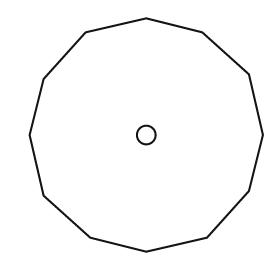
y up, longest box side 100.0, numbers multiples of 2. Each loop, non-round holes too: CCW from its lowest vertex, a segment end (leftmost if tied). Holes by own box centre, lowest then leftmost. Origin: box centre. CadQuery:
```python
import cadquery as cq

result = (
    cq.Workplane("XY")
    .moveTo(0.0, -50.0)
    .lineTo(26.0, -44.0)
    .lineTo(44.0, -24.0)
    .lineTo(50.0, 0.0)
    .lineTo(44.0, 26.0)
    .lineTo(24.0, 44.0)
    .lineTo(0.0, 50.0)
    .lineTo(-26.0, 44.0)
    .lineTo(-44.0, 24.0)
    .lineTo(-50.0, 0.0)
    .lineTo(-44.0, -26.0)
    .lineTo(-24.0, -44.0)
    .close()
    .moveTo(0.0, 0.0)
    .circle(4.0)
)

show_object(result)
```